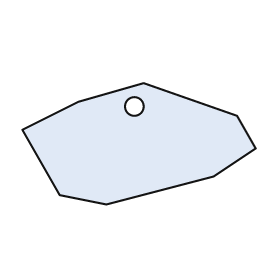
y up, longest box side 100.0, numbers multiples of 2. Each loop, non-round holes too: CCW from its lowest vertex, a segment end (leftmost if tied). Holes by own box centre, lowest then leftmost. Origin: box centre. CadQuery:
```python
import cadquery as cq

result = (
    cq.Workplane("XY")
    .moveTo(-14.0, -26.0)
    .lineTo(32.0, -14.0)
    .lineTo(50.0, -2.0)
    .lineTo(42.0, 12.0)
    .lineTo(2.0, 26.0)
    .lineTo(-26.0, 18.0)
    .lineTo(-50.0, 6.0)
    .lineTo(-34.0, -22.0)
    .close()
    .moveTo(-2.0, 16.0)
    .circle(4.0)
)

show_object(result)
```